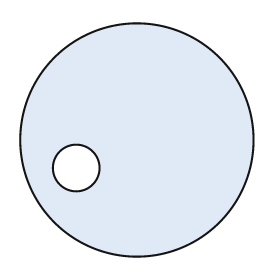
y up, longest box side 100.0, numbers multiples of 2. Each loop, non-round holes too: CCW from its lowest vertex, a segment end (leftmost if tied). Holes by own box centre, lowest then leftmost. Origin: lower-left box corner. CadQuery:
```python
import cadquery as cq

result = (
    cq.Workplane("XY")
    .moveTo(50.0, 50.0)
    .circle(50.0)
    .moveTo(24.0, 38.0)
    .circle(10.0)
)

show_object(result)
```